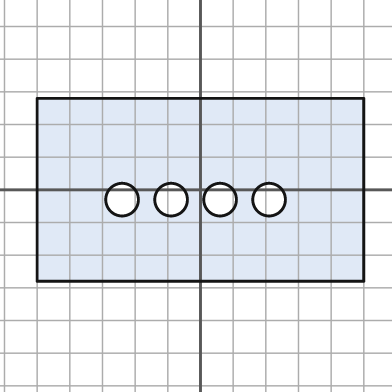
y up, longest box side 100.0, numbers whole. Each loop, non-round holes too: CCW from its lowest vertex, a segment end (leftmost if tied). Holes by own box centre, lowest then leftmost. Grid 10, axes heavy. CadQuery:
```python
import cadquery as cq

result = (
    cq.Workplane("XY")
    .moveTo(-50.0, -28.0)
    .lineTo(50.0, -28.0)
    .lineTo(50.0, 28.0)
    .lineTo(-50.0, 28.0)
    .close()
    .moveTo(-24.0, -3.0)
    .circle(5.0)
    .moveTo(-9.0, -3.0)
    .circle(5.0)
    .moveTo(6.0, -3.0)
    .circle(5.0)
    .moveTo(21.0, -3.0)
    .circle(5.0)
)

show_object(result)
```